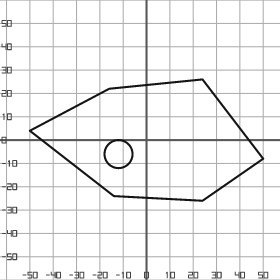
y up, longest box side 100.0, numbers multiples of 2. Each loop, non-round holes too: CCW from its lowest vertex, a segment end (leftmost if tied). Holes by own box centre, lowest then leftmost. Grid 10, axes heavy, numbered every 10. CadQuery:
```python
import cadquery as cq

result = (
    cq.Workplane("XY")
    .moveTo(24.0, -26.0)
    .lineTo(50.0, -8.0)
    .lineTo(24.0, 26.0)
    .lineTo(-16.0, 22.0)
    .lineTo(-50.0, 4.0)
    .lineTo(-14.0, -24.0)
    .close()
    .moveTo(-12.0, -6.0)
    .circle(6.0)
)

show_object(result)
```